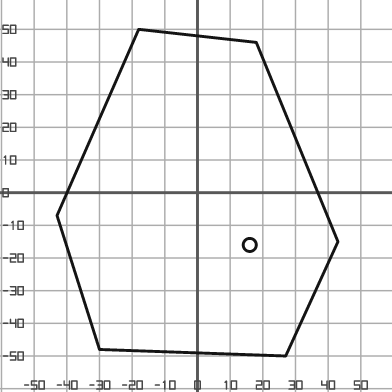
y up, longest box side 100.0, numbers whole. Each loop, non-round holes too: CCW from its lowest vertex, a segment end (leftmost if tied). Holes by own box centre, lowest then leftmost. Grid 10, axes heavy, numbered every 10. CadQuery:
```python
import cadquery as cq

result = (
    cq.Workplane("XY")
    .moveTo(27.0, -50.0)
    .lineTo(43.0, -15.0)
    .lineTo(18.0, 46.0)
    .lineTo(-18.0, 50.0)
    .lineTo(-43.0, -7.0)
    .lineTo(-30.0, -48.0)
    .close()
    .moveTo(16.0, -16.0)
    .circle(2.0)
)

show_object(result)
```